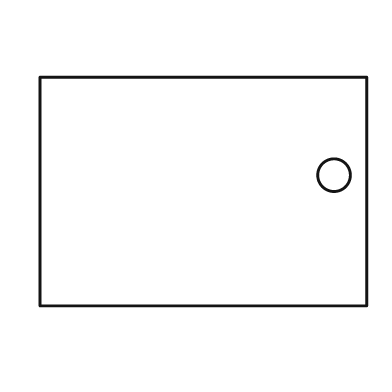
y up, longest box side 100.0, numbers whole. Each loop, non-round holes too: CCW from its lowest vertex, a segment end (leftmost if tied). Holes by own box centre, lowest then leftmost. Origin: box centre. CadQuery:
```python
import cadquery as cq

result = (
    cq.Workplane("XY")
    .moveTo(-50.0, -35.0)
    .lineTo(50.0, -35.0)
    .lineTo(50.0, 35.0)
    .lineTo(-50.0, 35.0)
    .close()
    .moveTo(40.0, 5.0)
    .circle(5.0)
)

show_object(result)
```